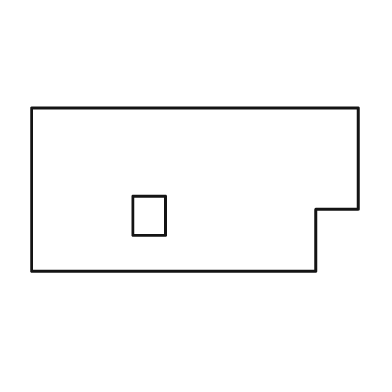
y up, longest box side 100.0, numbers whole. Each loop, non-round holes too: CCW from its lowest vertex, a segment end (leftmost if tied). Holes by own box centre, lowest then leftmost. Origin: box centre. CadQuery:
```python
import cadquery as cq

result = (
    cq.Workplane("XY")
    .moveTo(-50.0, -25.0)
    .lineTo(37.0, -25.0)
    .lineTo(37.0, -6.0)
    .lineTo(50.0, -6.0)
    .lineTo(50.0, 25.0)
    .lineTo(-50.0, 25.0)
    .close()
    .moveTo(-19.0, -14.0)
    .lineTo(-9.0, -14.0)
    .lineTo(-9.0, -2.0)
    .lineTo(-19.0, -2.0)
    .close()
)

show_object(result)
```